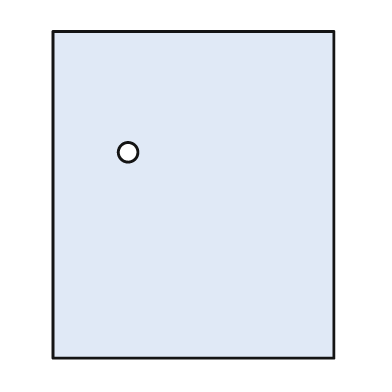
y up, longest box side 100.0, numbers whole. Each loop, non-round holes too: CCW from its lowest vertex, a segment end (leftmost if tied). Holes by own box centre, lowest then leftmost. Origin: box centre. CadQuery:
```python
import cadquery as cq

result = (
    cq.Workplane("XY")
    .moveTo(-43.0, -50.0)
    .lineTo(43.0, -50.0)
    .lineTo(43.0, 50.0)
    .lineTo(-43.0, 50.0)
    .close()
    .moveTo(-20.0, 13.0)
    .circle(3.0)
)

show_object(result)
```